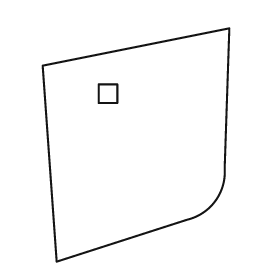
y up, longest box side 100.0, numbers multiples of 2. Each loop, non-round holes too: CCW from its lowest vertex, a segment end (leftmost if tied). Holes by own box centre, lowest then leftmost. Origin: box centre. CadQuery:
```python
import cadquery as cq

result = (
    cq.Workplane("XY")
    .moveTo(-34.0, -50.0)
    .lineTo(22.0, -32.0)
    .threePointArc((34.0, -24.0), (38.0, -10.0))
    .lineTo(40.0, 50.0)
    .lineTo(-40.0, 34.0)
    .close()
    .moveTo(-16.0, 18.0)
    .lineTo(-8.0, 18.0)
    .lineTo(-8.0, 26.0)
    .lineTo(-16.0, 26.0)
    .close()
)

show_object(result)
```